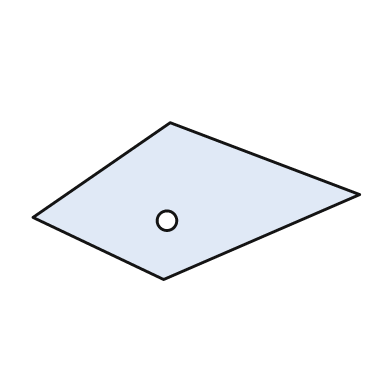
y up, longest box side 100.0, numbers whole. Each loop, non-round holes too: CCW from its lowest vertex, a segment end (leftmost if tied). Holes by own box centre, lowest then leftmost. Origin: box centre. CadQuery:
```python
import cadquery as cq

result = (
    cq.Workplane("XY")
    .moveTo(-10.0, -24.0)
    .lineTo(50.0, 2.0)
    .lineTo(-8.0, 24.0)
    .lineTo(-50.0, -5.0)
    .close()
    .moveTo(-9.0, -6.0)
    .circle(3.0)
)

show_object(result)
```